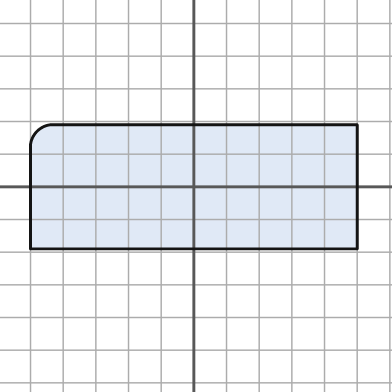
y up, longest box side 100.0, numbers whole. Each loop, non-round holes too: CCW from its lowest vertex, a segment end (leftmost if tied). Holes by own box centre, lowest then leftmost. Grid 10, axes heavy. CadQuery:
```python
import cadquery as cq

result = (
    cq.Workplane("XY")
    .moveTo(-50.0, -19.0)
    .lineTo(50.0, -19.0)
    .lineTo(50.0, 19.0)
    .lineTo(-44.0, 19.0)
    .threePointArc((-48.0, 17.0), (-50.0, 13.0))
    .close()
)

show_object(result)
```